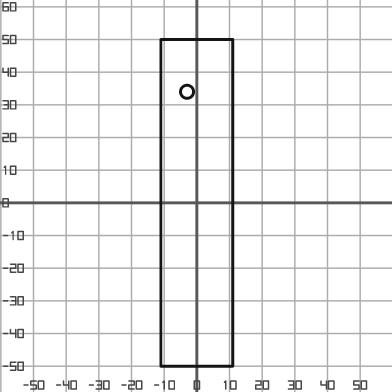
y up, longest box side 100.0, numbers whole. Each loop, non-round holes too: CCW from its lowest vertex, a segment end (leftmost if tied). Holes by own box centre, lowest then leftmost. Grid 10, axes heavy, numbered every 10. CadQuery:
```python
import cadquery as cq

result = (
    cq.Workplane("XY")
    .moveTo(-11.0, -50.0)
    .lineTo(11.0, -50.0)
    .lineTo(11.0, 50.0)
    .lineTo(-11.0, 50.0)
    .close()
    .moveTo(-3.0, 34.0)
    .circle(2.0)
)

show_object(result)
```